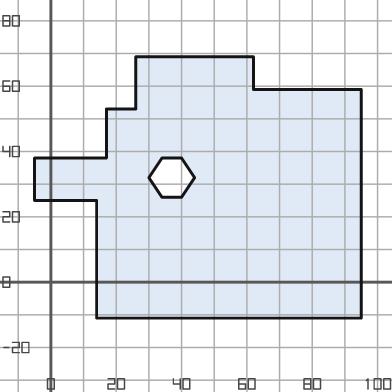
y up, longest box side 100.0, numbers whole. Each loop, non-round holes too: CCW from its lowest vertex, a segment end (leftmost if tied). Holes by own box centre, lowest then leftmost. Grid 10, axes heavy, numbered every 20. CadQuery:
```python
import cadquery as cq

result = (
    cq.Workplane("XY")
    .moveTo(14.0, -11.0)
    .lineTo(95.0, -11.0)
    .lineTo(95.0, 59.0)
    .lineTo(62.0, 59.0)
    .lineTo(62.0, 69.0)
    .lineTo(26.0, 69.0)
    .lineTo(26.0, 53.0)
    .lineTo(17.0, 53.0)
    .lineTo(17.0, 38.0)
    .lineTo(-5.0, 38.0)
    .lineTo(-5.0, 25.0)
    .lineTo(14.0, 25.0)
    .close()
    .moveTo(34.0, 26.0)
    .lineTo(40.0, 26.0)
    .lineTo(44.0, 32.0)
    .lineTo(40.0, 38.0)
    .lineTo(34.0, 38.0)
    .lineTo(30.0, 32.0)
    .close()
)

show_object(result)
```